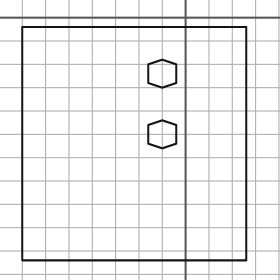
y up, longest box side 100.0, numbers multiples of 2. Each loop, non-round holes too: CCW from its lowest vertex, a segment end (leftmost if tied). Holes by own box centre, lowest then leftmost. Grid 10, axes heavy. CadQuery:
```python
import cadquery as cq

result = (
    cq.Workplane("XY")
    .moveTo(-70.0, -104.0)
    .lineTo(26.0, -104.0)
    .lineTo(26.0, -4.0)
    .lineTo(-70.0, -4.0)
    .close()
    .moveTo(-10.0, -56.0)
    .lineTo(-4.0, -54.0)
    .lineTo(-4.0, -46.0)
    .lineTo(-10.0, -44.0)
    .lineTo(-16.0, -46.0)
    .lineTo(-16.0, -54.0)
    .close()
    .moveTo(-10.0, -30.0)
    .lineTo(-4.0, -28.0)
    .lineTo(-4.0, -20.0)
    .lineTo(-10.0, -18.0)
    .lineTo(-16.0, -20.0)
    .lineTo(-16.0, -28.0)
    .close()
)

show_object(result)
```